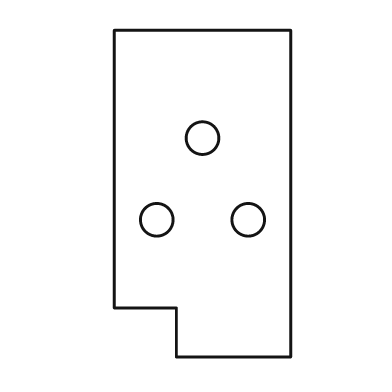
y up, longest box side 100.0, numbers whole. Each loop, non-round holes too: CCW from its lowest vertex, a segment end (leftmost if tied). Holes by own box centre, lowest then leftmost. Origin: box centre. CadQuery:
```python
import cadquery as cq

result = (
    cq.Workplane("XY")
    .moveTo(-8.0, -50.0)
    .lineTo(27.0, -50.0)
    .lineTo(27.0, 50.0)
    .lineTo(-27.0, 50.0)
    .lineTo(-27.0, -35.0)
    .lineTo(-8.0, -35.0)
    .close()
    .moveTo(-14.0, -8.0)
    .circle(5.0)
    .moveTo(14.0, -8.0)
    .circle(5.0)
    .moveTo(0.0, 17.0)
    .circle(5.0)
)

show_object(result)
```